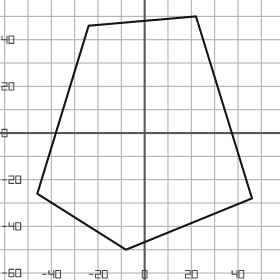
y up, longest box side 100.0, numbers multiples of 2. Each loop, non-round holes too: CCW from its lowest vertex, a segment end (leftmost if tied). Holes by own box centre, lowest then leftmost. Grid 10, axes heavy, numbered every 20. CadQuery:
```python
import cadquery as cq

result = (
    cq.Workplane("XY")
    .moveTo(-8.0, -50.0)
    .lineTo(46.0, -28.0)
    .lineTo(22.0, 50.0)
    .lineTo(-24.0, 46.0)
    .lineTo(-46.0, -26.0)
    .close()
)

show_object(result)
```